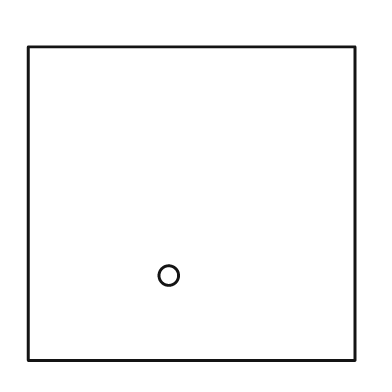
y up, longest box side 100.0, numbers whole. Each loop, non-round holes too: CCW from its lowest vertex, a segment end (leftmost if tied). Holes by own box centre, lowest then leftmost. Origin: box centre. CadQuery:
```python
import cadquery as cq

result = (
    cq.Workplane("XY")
    .moveTo(-50.0, -48.0)
    .lineTo(50.0, -48.0)
    .lineTo(50.0, 48.0)
    .lineTo(-50.0, 48.0)
    .close()
    .moveTo(-7.0, -22.0)
    .circle(3.0)
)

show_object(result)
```